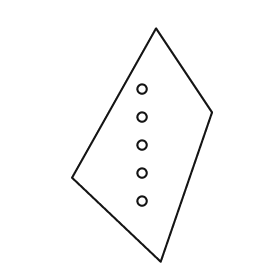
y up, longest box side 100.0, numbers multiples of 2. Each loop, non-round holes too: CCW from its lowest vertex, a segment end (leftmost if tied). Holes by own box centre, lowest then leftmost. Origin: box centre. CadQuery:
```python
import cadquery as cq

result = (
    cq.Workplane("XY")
    .moveTo(8.0, -50.0)
    .lineTo(30.0, 14.0)
    .lineTo(6.0, 50.0)
    .lineTo(-30.0, -14.0)
    .close()
    .moveTo(0.0, -24.0)
    .circle(2.0)
    .moveTo(0.0, -12.0)
    .circle(2.0)
    .moveTo(0.0, 0.0)
    .circle(2.0)
    .moveTo(0.0, 12.0)
    .circle(2.0)
    .moveTo(0.0, 24.0)
    .circle(2.0)
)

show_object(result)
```